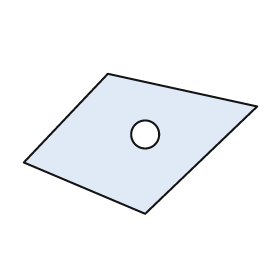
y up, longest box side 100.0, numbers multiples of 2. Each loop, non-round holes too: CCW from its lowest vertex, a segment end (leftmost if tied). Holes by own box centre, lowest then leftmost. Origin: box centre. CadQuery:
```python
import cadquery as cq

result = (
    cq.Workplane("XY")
    .moveTo(2.0, -30.0)
    .lineTo(50.0, 16.0)
    .lineTo(-14.0, 30.0)
    .lineTo(-50.0, -8.0)
    .close()
    .moveTo(2.0, 4.0)
    .circle(6.0)
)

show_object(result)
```